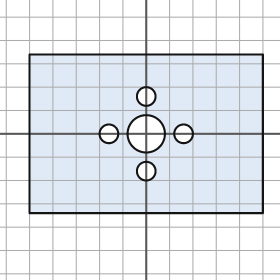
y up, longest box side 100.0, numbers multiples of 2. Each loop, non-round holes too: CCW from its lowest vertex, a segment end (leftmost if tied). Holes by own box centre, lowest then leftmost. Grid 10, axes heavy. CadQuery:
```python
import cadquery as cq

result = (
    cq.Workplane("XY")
    .moveTo(-50.0, -34.0)
    .lineTo(50.0, -34.0)
    .lineTo(50.0, 34.0)
    .lineTo(-50.0, 34.0)
    .close()
    .moveTo(0.0, -16.0)
    .circle(4.0)
    .moveTo(-16.0, 0.0)
    .circle(4.0)
    .moveTo(0.0, 0.0)
    .circle(8.0)
    .moveTo(16.0, 0.0)
    .circle(4.0)
    .moveTo(0.0, 16.0)
    .circle(4.0)
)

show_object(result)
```